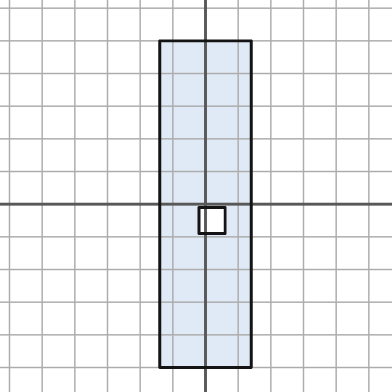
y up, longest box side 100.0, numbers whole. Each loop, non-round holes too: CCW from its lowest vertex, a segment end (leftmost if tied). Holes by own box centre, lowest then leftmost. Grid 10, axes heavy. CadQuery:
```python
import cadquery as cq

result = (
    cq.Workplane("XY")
    .moveTo(-14.0, -50.0)
    .lineTo(14.0, -50.0)
    .lineTo(14.0, 50.0)
    .lineTo(-14.0, 50.0)
    .close()
    .moveTo(-2.0, -9.0)
    .lineTo(6.0, -9.0)
    .lineTo(6.0, -1.0)
    .lineTo(-2.0, -1.0)
    .close()
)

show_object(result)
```